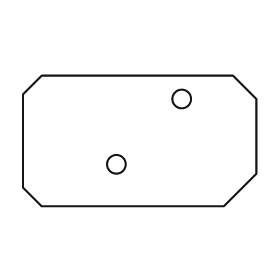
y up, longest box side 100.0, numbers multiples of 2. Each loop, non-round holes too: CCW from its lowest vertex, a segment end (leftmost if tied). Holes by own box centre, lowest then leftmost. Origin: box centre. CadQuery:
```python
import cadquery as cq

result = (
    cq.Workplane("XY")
    .moveTo(-42.0, -28.0)
    .lineTo(36.0, -28.0)
    .lineTo(50.0, -14.0)
    .lineTo(50.0, 18.0)
    .lineTo(40.0, 28.0)
    .lineTo(-42.0, 28.0)
    .lineTo(-50.0, 20.0)
    .lineTo(-50.0, -20.0)
    .close()
    .moveTo(-10.0, -10.0)
    .circle(4.0)
    .moveTo(18.0, 18.0)
    .circle(4.0)
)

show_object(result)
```